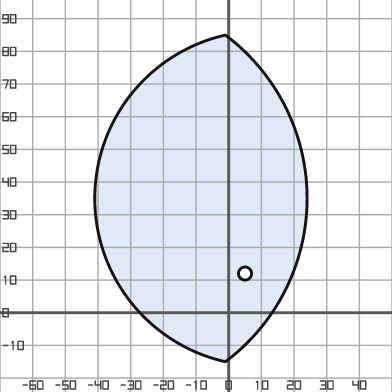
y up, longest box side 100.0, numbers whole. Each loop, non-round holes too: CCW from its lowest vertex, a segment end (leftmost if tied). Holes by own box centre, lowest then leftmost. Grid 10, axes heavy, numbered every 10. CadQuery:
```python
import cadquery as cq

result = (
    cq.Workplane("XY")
    .moveTo(-1.0, -15.0)
    .threePointArc((24.0, 35.0), (-1.0, 85.0))
    .threePointArc((-41.0, 35.0), (-1.0, -15.0))
    .close()
    .moveTo(5.0, 12.0)
    .circle(2.0)
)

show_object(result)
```